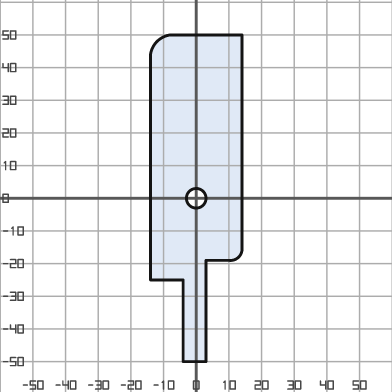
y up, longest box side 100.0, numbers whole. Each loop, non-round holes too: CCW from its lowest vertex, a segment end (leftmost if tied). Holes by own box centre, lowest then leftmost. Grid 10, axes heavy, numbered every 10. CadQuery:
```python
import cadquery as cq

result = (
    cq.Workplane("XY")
    .moveTo(-4.0, -50.0)
    .lineTo(3.0, -50.0)
    .lineTo(3.0, -19.0)
    .lineTo(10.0, -19.0)
    .threePointArc((13.0, -18.0), (14.0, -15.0))
    .lineTo(14.0, 50.0)
    .lineTo(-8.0, 50.0)
    .threePointArc((-12.0, 48.0), (-14.0, 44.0))
    .lineTo(-14.0, -25.0)
    .lineTo(-4.0, -25.0)
    .close()
    .moveTo(0.0, 0.0)
    .circle(3.0)
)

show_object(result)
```